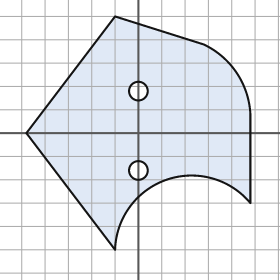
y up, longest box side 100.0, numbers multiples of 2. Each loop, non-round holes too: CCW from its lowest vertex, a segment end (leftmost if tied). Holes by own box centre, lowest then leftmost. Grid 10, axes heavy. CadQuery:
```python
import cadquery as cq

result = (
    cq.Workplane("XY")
    .moveTo(-10.0, -50.0)
    .threePointArc((12.0, -20.0), (48.0, -30.0))
    .lineTo(48.0, 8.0)
    .threePointArc((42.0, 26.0), (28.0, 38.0))
    .lineTo(-10.0, 50.0)
    .lineTo(-48.0, 0.0)
    .close()
    .moveTo(0.0, -16.0)
    .circle(4.0)
    .moveTo(0.0, 18.0)
    .circle(4.0)
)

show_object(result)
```